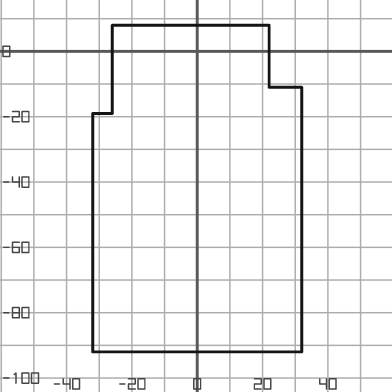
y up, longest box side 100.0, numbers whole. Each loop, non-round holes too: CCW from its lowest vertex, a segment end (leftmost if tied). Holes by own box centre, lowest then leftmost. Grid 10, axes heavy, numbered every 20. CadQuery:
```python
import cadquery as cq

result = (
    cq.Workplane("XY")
    .moveTo(-32.0, -92.0)
    .lineTo(32.0, -92.0)
    .lineTo(32.0, -11.0)
    .lineTo(22.0, -11.0)
    .lineTo(22.0, 8.0)
    .lineTo(-26.0, 8.0)
    .lineTo(-26.0, -19.0)
    .lineTo(-32.0, -19.0)
    .close()
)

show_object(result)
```